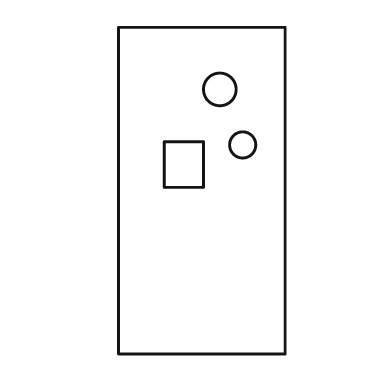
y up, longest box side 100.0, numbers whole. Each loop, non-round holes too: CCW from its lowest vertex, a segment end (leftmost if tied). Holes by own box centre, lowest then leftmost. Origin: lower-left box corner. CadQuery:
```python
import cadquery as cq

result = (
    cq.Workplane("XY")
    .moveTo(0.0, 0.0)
    .lineTo(51.0, 0.0)
    .lineTo(51.0, 100.0)
    .lineTo(0.0, 100.0)
    .close()
    .moveTo(14.0, 51.0)
    .lineTo(26.0, 51.0)
    .lineTo(26.0, 65.0)
    .lineTo(14.0, 65.0)
    .close()
    .moveTo(38.0, 64.0)
    .circle(4.0)
    .moveTo(31.0, 81.0)
    .circle(5.0)
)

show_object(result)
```